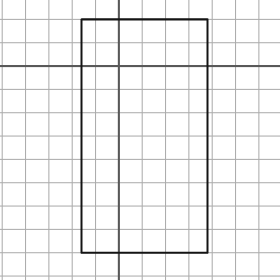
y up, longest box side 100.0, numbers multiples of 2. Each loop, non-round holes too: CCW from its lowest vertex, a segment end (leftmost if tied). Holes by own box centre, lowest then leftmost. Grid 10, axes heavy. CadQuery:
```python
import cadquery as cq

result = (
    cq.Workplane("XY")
    .moveTo(-16.0, -80.0)
    .lineTo(38.0, -80.0)
    .lineTo(38.0, 20.0)
    .lineTo(-16.0, 20.0)
    .close()
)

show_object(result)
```